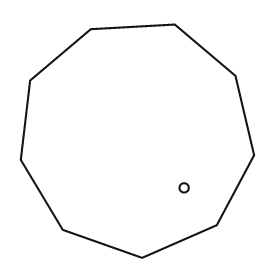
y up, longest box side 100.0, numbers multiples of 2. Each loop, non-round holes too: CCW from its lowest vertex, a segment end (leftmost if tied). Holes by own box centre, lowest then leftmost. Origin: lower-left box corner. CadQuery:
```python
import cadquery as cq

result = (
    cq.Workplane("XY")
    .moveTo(52.0, 0.0)
    .lineTo(84.0, 14.0)
    .lineTo(100.0, 44.0)
    .lineTo(92.0, 78.0)
    .lineTo(66.0, 100.0)
    .lineTo(30.0, 98.0)
    .lineTo(4.0, 76.0)
    .lineTo(0.0, 42.0)
    .lineTo(18.0, 12.0)
    .close()
    .moveTo(70.0, 30.0)
    .circle(2.0)
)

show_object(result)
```